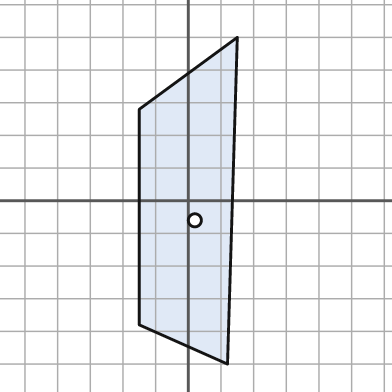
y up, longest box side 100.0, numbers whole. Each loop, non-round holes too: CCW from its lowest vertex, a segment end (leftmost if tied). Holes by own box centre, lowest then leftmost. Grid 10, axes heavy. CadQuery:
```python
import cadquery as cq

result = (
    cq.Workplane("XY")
    .moveTo(12.0, -50.0)
    .lineTo(15.0, 50.0)
    .lineTo(-15.0, 28.0)
    .lineTo(-15.0, -38.0)
    .close()
    .moveTo(2.0, -6.0)
    .circle(2.0)
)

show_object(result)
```